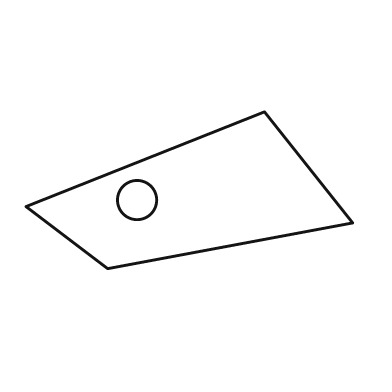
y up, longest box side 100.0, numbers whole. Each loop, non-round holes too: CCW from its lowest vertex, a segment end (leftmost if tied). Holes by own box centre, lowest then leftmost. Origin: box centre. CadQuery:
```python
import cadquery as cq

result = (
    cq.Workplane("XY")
    .moveTo(-25.0, -24.0)
    .lineTo(50.0, -10.0)
    .lineTo(23.0, 24.0)
    .lineTo(-50.0, -5.0)
    .close()
    .moveTo(-16.0, -3.0)
    .circle(6.0)
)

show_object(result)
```